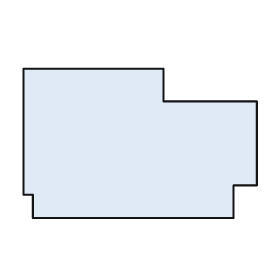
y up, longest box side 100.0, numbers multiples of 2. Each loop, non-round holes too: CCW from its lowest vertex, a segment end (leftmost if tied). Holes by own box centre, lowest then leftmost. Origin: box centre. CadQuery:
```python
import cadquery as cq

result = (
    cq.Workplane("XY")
    .moveTo(-46.0, -32.0)
    .lineTo(40.0, -32.0)
    .lineTo(40.0, -18.0)
    .lineTo(50.0, -18.0)
    .lineTo(50.0, 18.0)
    .lineTo(10.0, 18.0)
    .lineTo(10.0, 32.0)
    .lineTo(-50.0, 32.0)
    .lineTo(-50.0, -22.0)
    .lineTo(-46.0, -22.0)
    .close()
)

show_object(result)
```